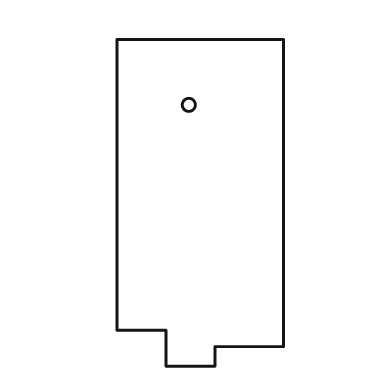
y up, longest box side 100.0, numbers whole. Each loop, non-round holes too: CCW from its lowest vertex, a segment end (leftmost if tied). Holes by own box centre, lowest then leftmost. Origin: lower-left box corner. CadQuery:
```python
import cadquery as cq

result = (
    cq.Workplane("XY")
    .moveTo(15.0, 0.0)
    .lineTo(30.0, 0.0)
    .lineTo(30.0, 6.0)
    .lineTo(51.0, 6.0)
    .lineTo(51.0, 100.0)
    .lineTo(0.0, 100.0)
    .lineTo(0.0, 11.0)
    .lineTo(15.0, 11.0)
    .close()
    .moveTo(22.0, 80.0)
    .circle(2.0)
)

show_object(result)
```